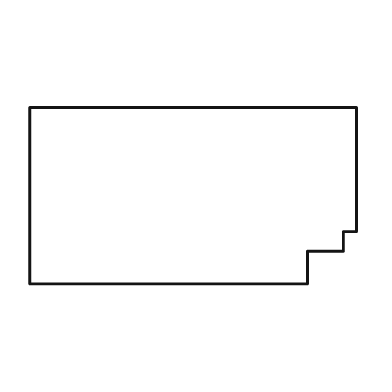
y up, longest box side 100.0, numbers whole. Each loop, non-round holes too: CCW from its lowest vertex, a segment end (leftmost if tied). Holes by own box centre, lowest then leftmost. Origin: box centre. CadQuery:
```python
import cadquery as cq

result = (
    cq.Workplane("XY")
    .moveTo(-50.0, -27.0)
    .lineTo(35.0, -27.0)
    .lineTo(35.0, -17.0)
    .lineTo(46.0, -17.0)
    .lineTo(46.0, -11.0)
    .lineTo(50.0, -11.0)
    .lineTo(50.0, 27.0)
    .lineTo(-50.0, 27.0)
    .close()
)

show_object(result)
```